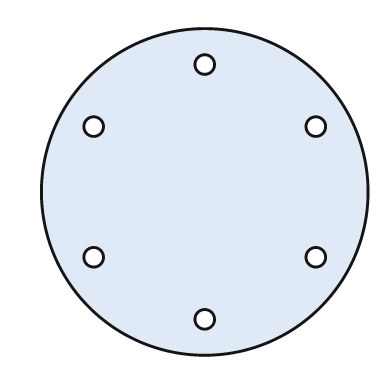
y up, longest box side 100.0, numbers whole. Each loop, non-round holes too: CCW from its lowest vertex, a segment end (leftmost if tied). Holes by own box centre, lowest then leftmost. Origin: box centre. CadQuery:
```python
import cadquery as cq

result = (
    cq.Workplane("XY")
    .moveTo(0.0, 0.0)
    .circle(50.0)
    .moveTo(0.0, -39.0)
    .circle(3.0)
    .moveTo(-34.0, -20.0)
    .circle(3.0)
    .moveTo(34.0, -20.0)
    .circle(3.0)
    .moveTo(-34.0, 20.0)
    .circle(3.0)
    .moveTo(34.0, 20.0)
    .circle(3.0)
    .moveTo(0.0, 39.0)
    .circle(3.0)
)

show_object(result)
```